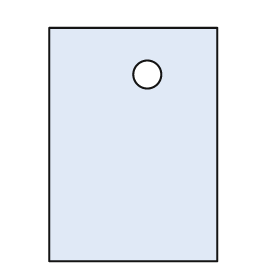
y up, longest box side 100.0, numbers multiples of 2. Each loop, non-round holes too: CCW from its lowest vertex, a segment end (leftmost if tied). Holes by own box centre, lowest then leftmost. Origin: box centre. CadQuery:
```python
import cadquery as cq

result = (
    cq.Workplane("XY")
    .moveTo(-36.0, -50.0)
    .lineTo(36.0, -50.0)
    .lineTo(36.0, 50.0)
    .lineTo(-36.0, 50.0)
    .close()
    .moveTo(6.0, 30.0)
    .circle(6.0)
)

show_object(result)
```